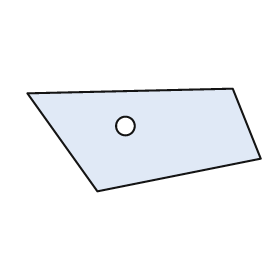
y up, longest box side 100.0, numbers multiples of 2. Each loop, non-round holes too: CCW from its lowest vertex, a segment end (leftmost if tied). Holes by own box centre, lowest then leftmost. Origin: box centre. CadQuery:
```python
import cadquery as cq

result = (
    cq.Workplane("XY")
    .moveTo(-20.0, -22.0)
    .lineTo(50.0, -8.0)
    .lineTo(38.0, 22.0)
    .lineTo(-50.0, 20.0)
    .close()
    .moveTo(-8.0, 6.0)
    .circle(4.0)
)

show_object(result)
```